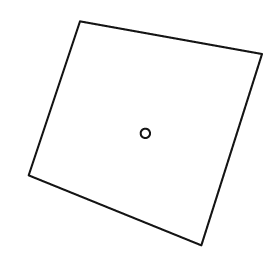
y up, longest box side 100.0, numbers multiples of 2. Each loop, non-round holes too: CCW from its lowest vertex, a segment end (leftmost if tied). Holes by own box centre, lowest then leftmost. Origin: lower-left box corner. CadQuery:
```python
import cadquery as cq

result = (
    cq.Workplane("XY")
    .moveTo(74.0, 0.0)
    .lineTo(100.0, 82.0)
    .lineTo(22.0, 96.0)
    .lineTo(0.0, 30.0)
    .close()
    .moveTo(50.0, 48.0)
    .circle(2.0)
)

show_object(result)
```